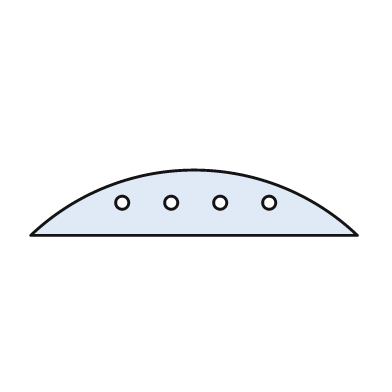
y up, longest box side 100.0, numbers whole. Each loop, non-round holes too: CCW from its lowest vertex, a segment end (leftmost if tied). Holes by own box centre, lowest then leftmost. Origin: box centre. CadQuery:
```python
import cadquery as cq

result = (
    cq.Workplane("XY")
    .moveTo(-50.0, -10.0)
    .lineTo(50.0, -10.0)
    .threePointArc((0.0, 10.0), (-50.0, -10.0))
    .close()
    .moveTo(-22.0, 0.0)
    .circle(2.0)
    .moveTo(-7.0, 0.0)
    .circle(2.0)
    .moveTo(8.0, 0.0)
    .circle(2.0)
    .moveTo(23.0, 0.0)
    .circle(2.0)
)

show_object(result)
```